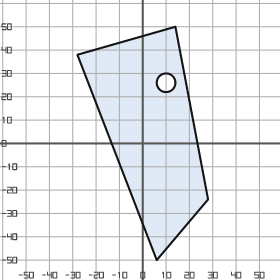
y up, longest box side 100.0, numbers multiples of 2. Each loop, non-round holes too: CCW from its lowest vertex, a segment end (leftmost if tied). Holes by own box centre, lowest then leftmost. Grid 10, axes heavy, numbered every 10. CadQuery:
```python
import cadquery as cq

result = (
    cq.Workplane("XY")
    .moveTo(6.0, -50.0)
    .lineTo(28.0, -24.0)
    .lineTo(14.0, 50.0)
    .lineTo(-28.0, 38.0)
    .close()
    .moveTo(10.0, 26.0)
    .circle(4.0)
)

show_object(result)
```